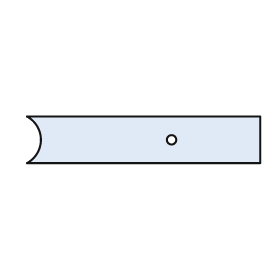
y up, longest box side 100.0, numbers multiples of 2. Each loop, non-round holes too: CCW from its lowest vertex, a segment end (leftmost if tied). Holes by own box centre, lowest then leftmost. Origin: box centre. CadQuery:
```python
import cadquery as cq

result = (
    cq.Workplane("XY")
    .moveTo(-50.0, -10.0)
    .lineTo(50.0, -10.0)
    .lineTo(50.0, 10.0)
    .lineTo(-50.0, 10.0)
    .threePointArc((-44.0, 0.0), (-50.0, -10.0))
    .close()
    .moveTo(12.0, 0.0)
    .circle(2.0)
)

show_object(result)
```